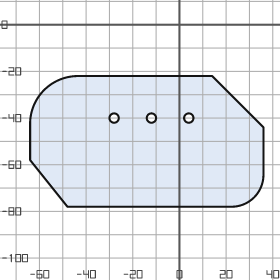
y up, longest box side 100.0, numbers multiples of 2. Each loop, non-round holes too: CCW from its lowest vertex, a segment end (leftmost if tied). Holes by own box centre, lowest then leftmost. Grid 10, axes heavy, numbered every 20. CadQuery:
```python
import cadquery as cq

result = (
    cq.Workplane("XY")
    .moveTo(-48.0, -78.0)
    .lineTo(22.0, -78.0)
    .threePointArc((32.0, -74.0), (36.0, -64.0))
    .lineTo(36.0, -44.0)
    .lineTo(14.0, -22.0)
    .lineTo(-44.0, -22.0)
    .threePointArc((-58.0, -28.0), (-64.0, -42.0))
    .lineTo(-64.0, -58.0)
    .close()
    .moveTo(-28.0, -40.0)
    .circle(2.0)
    .moveTo(-12.0, -40.0)
    .circle(2.0)
    .moveTo(4.0, -40.0)
    .circle(2.0)
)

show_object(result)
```